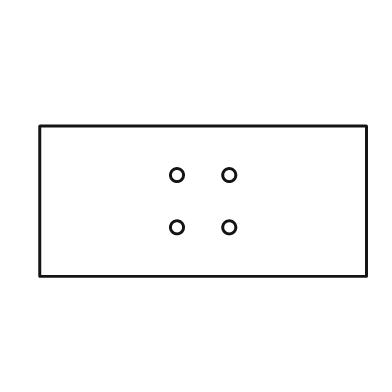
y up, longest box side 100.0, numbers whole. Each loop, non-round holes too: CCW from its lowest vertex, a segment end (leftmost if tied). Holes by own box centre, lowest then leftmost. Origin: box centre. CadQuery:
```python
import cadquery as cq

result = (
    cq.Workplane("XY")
    .moveTo(-50.0, -23.0)
    .lineTo(50.0, -23.0)
    .lineTo(50.0, 23.0)
    .lineTo(-50.0, 23.0)
    .close()
    .moveTo(-8.0, -8.0)
    .circle(2.0)
    .moveTo(8.0, -8.0)
    .circle(2.0)
    .moveTo(-8.0, 8.0)
    .circle(2.0)
    .moveTo(8.0, 8.0)
    .circle(2.0)
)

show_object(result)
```